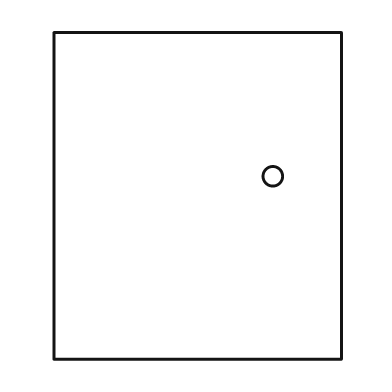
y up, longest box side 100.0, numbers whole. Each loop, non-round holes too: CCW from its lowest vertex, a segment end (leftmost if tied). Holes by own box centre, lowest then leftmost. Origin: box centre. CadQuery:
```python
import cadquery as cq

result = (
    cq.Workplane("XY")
    .moveTo(-44.0, -50.0)
    .lineTo(44.0, -50.0)
    .lineTo(44.0, 50.0)
    .lineTo(-44.0, 50.0)
    .close()
    .moveTo(23.0, 6.0)
    .circle(3.0)
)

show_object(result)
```